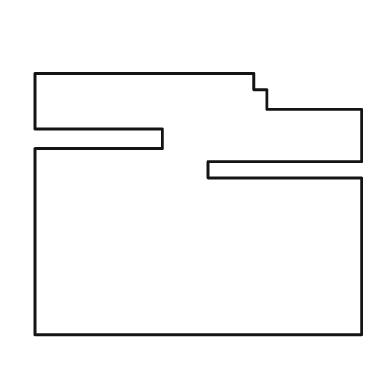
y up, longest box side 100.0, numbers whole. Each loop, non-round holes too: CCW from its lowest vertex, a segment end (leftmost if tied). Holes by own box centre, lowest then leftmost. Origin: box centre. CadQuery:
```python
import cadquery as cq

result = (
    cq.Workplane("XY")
    .moveTo(-50.0, -40.0)
    .lineTo(50.0, -40.0)
    .lineTo(50.0, 8.0)
    .lineTo(3.0, 8.0)
    .lineTo(3.0, 13.0)
    .lineTo(50.0, 13.0)
    .lineTo(50.0, 29.0)
    .lineTo(21.0, 29.0)
    .lineTo(21.0, 35.0)
    .lineTo(17.0, 35.0)
    .lineTo(17.0, 40.0)
    .lineTo(-50.0, 40.0)
    .lineTo(-50.0, 23.0)
    .lineTo(-11.0, 23.0)
    .lineTo(-11.0, 17.0)
    .lineTo(-50.0, 17.0)
    .close()
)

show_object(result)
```